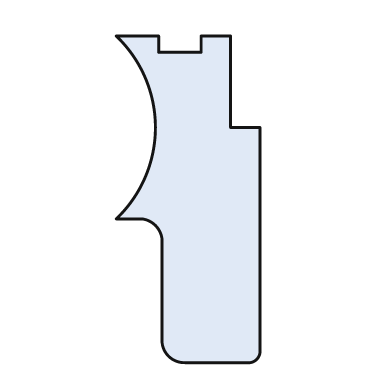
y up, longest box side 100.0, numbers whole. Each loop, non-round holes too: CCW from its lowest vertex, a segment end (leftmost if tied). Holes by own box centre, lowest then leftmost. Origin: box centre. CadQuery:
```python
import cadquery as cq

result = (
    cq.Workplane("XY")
    .moveTo(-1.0, -50.0)
    .lineTo(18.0, -50.0)
    .threePointArc((21.0, -49.0), (22.0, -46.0))
    .lineTo(22.0, 22.0)
    .lineTo(13.0, 22.0)
    .lineTo(13.0, 50.0)
    .lineTo(4.0, 50.0)
    .lineTo(4.0, 45.0)
    .lineTo(-9.0, 45.0)
    .lineTo(-9.0, 50.0)
    .lineTo(-22.0, 50.0)
    .threePointArc((-10.0, 22.0), (-22.0, -6.0))
    .lineTo(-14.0, -6.0)
    .threePointArc((-10.0, -8.0), (-8.0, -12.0))
    .lineTo(-8.0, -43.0)
    .threePointArc((-6.0, -48.0), (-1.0, -50.0))
    .close()
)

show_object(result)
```